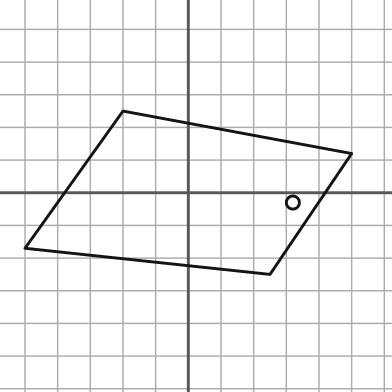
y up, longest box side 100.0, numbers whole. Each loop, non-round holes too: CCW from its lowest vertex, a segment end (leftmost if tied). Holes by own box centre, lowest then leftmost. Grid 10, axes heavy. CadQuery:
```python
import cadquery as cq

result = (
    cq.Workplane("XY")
    .moveTo(25.0, -25.0)
    .lineTo(50.0, 12.0)
    .lineTo(-20.0, 25.0)
    .lineTo(-50.0, -17.0)
    .close()
    .moveTo(32.0, -3.0)
    .circle(2.0)
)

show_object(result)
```